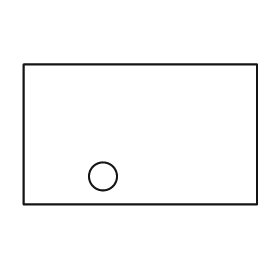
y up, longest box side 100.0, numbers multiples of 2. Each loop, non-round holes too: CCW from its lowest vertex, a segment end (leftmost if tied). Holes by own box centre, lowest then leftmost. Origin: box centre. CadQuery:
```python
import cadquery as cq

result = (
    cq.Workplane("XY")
    .moveTo(-50.0, -30.0)
    .lineTo(50.0, -30.0)
    .lineTo(50.0, 30.0)
    .lineTo(-50.0, 30.0)
    .close()
    .moveTo(-16.0, -18.0)
    .circle(6.0)
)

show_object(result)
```